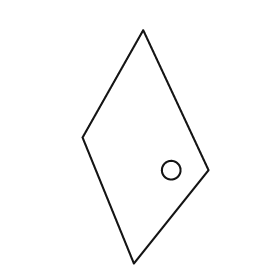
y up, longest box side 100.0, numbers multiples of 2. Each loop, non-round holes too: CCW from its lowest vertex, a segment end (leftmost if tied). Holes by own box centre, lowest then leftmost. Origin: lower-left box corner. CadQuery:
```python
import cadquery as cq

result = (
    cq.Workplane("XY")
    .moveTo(22.0, 0.0)
    .lineTo(54.0, 40.0)
    .lineTo(26.0, 100.0)
    .lineTo(0.0, 54.0)
    .close()
    .moveTo(38.0, 40.0)
    .circle(4.0)
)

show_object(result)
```